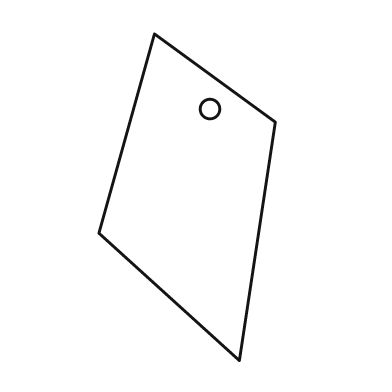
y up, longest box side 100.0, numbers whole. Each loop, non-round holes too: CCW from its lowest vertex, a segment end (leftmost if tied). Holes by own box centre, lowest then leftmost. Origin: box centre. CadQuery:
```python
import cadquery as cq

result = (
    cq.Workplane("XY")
    .moveTo(16.0, -50.0)
    .lineTo(27.0, 23.0)
    .lineTo(-10.0, 50.0)
    .lineTo(-27.0, -11.0)
    .close()
    .moveTo(7.0, 27.0)
    .circle(3.0)
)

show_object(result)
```